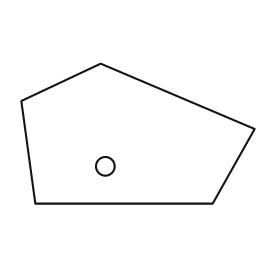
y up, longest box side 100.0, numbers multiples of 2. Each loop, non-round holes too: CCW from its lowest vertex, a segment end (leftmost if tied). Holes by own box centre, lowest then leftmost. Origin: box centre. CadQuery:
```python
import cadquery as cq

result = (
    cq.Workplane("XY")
    .moveTo(-44.0, -30.0)
    .lineTo(32.0, -30.0)
    .lineTo(50.0, 2.0)
    .lineTo(-16.0, 30.0)
    .lineTo(-50.0, 14.0)
    .close()
    .moveTo(-14.0, -14.0)
    .circle(4.0)
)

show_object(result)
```